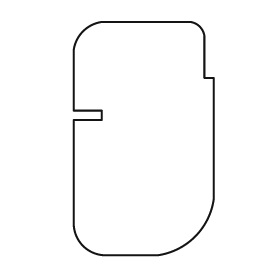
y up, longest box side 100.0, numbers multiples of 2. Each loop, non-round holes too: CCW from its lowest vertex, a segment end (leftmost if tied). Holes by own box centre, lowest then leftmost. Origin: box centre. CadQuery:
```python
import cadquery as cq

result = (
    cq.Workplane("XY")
    .moveTo(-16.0, -50.0)
    .lineTo(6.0, -50.0)
    .threePointArc((22.0, -42.0), (30.0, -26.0))
    .lineTo(30.0, 26.0)
    .lineTo(26.0, 26.0)
    .lineTo(26.0, 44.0)
    .threePointArc((24.0, 48.0), (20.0, 50.0))
    .lineTo(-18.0, 50.0)
    .threePointArc((-26.0, 46.0), (-30.0, 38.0))
    .lineTo(-30.0, 12.0)
    .lineTo(-18.0, 12.0)
    .lineTo(-18.0, 8.0)
    .lineTo(-30.0, 8.0)
    .lineTo(-30.0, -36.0)
    .threePointArc((-26.0, -46.0), (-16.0, -50.0))
    .close()
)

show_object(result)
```